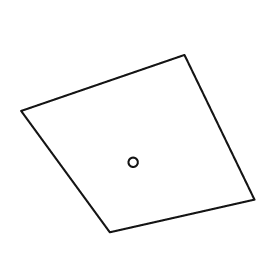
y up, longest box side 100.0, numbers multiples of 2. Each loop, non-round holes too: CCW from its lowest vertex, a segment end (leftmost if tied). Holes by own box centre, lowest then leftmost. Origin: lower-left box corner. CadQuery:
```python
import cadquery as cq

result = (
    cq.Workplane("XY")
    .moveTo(38.0, 0.0)
    .lineTo(100.0, 14.0)
    .lineTo(70.0, 76.0)
    .lineTo(0.0, 52.0)
    .close()
    .moveTo(48.0, 30.0)
    .circle(2.0)
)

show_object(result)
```